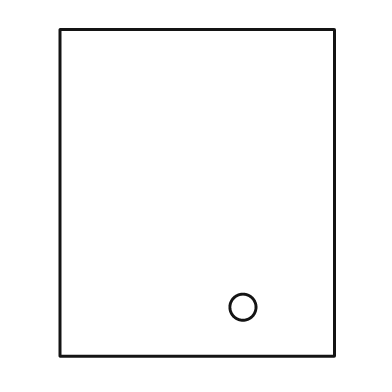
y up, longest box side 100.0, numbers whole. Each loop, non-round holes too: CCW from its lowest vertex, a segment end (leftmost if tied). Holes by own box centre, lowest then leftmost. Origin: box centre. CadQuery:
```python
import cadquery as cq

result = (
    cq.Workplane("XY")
    .moveTo(-42.0, -50.0)
    .lineTo(42.0, -50.0)
    .lineTo(42.0, 50.0)
    .lineTo(-42.0, 50.0)
    .close()
    .moveTo(14.0, -35.0)
    .circle(4.0)
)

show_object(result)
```